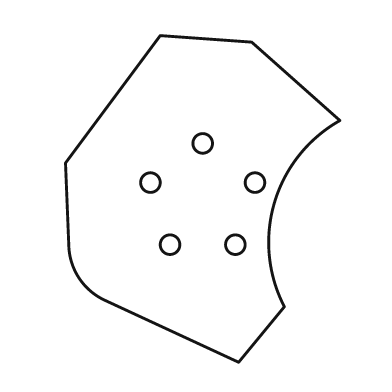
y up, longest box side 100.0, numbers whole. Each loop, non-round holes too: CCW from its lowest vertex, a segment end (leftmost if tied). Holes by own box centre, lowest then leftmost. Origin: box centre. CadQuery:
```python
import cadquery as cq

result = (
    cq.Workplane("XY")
    .moveTo(11.0, -50.0)
    .lineTo(25.0, -33.0)
    .threePointArc((22.0, -1.0), (42.0, 24.0))
    .lineTo(15.0, 48.0)
    .lineTo(-13.0, 50.0)
    .lineTo(-42.0, 11.0)
    .lineTo(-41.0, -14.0)
    .threePointArc((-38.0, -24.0), (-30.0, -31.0))
    .close()
    .moveTo(-10.0, -14.0)
    .circle(3.0)
    .moveTo(10.0, -14.0)
    .circle(3.0)
    .moveTo(-16.0, 5.0)
    .circle(3.0)
    .moveTo(16.0, 5.0)
    .circle(3.0)
    .moveTo(0.0, 17.0)
    .circle(3.0)
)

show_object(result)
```